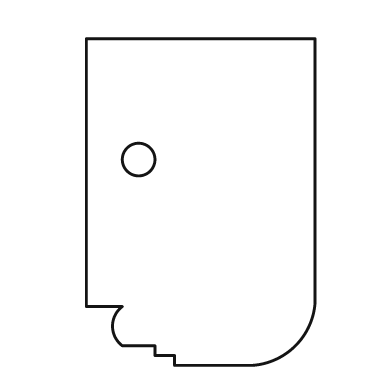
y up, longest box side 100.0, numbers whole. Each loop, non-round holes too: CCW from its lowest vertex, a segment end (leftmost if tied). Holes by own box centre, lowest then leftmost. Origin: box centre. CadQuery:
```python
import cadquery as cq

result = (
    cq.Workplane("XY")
    .moveTo(-8.0, -50.0)
    .lineTo(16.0, -50.0)
    .threePointArc((29.0, -44.0), (35.0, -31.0))
    .lineTo(35.0, 50.0)
    .lineTo(-35.0, 50.0)
    .lineTo(-35.0, -32.0)
    .lineTo(-24.0, -32.0)
    .threePointArc((-27.0, -38.0), (-24.0, -44.0))
    .lineTo(-14.0, -44.0)
    .lineTo(-14.0, -47.0)
    .lineTo(-8.0, -47.0)
    .close()
    .moveTo(-19.0, 13.0)
    .circle(5.0)
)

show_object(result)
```